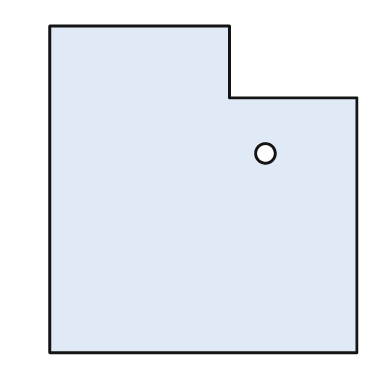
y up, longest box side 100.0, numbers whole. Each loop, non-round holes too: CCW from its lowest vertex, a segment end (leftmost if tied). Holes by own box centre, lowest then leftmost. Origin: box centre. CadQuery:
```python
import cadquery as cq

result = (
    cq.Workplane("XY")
    .moveTo(-47.0, -50.0)
    .lineTo(47.0, -50.0)
    .lineTo(47.0, 28.0)
    .lineTo(8.0, 28.0)
    .lineTo(8.0, 50.0)
    .lineTo(-47.0, 50.0)
    .close()
    .moveTo(19.0, 11.0)
    .circle(3.0)
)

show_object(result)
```